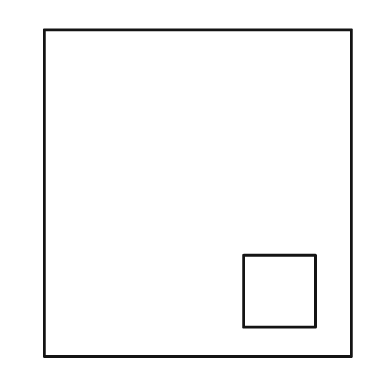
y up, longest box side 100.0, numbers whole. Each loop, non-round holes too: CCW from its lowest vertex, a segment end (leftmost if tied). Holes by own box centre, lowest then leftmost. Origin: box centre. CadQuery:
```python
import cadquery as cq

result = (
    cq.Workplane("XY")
    .moveTo(-47.0, -50.0)
    .lineTo(47.0, -50.0)
    .lineTo(47.0, 50.0)
    .lineTo(-47.0, 50.0)
    .close()
    .moveTo(14.0, -41.0)
    .lineTo(36.0, -41.0)
    .lineTo(36.0, -19.0)
    .lineTo(14.0, -19.0)
    .close()
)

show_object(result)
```